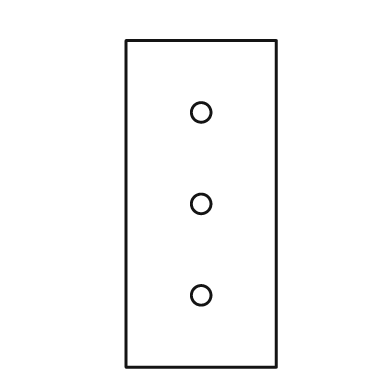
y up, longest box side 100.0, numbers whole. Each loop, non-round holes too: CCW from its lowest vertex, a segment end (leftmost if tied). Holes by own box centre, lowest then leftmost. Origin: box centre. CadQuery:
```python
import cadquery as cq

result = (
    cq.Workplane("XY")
    .moveTo(-23.0, -50.0)
    .lineTo(23.0, -50.0)
    .lineTo(23.0, 50.0)
    .lineTo(-23.0, 50.0)
    .close()
    .moveTo(0.0, -28.0)
    .circle(3.0)
    .moveTo(0.0, 0.0)
    .circle(3.0)
    .moveTo(0.0, 28.0)
    .circle(3.0)
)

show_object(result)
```